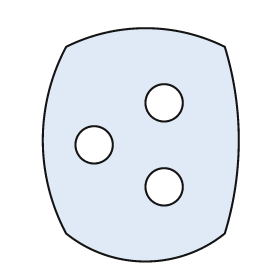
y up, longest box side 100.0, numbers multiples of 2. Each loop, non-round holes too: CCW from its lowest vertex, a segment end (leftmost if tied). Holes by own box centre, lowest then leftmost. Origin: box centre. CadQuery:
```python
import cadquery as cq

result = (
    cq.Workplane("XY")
    .moveTo(-32.0, -38.0)
    .threePointArc((2.0, -50.0), (36.0, -38.0))
    .threePointArc((42.0, 2.0), (36.0, 42.0))
    .threePointArc((2.0, 50.0), (-32.0, 42.0))
    .threePointArc((-42.0, 2.0), (-32.0, -38.0))
    .close()
    .moveTo(10.0, -18.0)
    .circle(8.0)
    .moveTo(-20.0, 0.0)
    .circle(8.0)
    .moveTo(10.0, 18.0)
    .circle(8.0)
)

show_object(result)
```